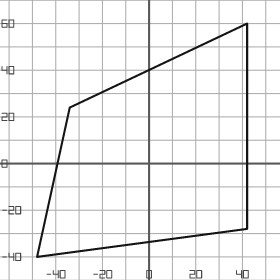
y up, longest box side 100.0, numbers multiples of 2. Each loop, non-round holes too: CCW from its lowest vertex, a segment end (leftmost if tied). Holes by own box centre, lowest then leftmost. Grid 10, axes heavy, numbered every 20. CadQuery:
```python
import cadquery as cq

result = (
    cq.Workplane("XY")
    .moveTo(-48.0, -40.0)
    .lineTo(42.0, -28.0)
    .lineTo(42.0, 60.0)
    .lineTo(-34.0, 24.0)
    .close()
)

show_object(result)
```